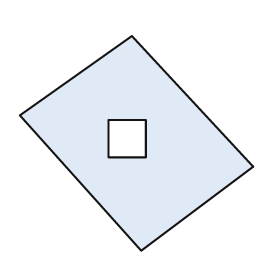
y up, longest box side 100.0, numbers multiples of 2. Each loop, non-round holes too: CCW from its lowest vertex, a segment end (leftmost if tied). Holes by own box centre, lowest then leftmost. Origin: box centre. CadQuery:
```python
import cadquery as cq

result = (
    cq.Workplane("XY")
    .moveTo(2.0, -46.0)
    .lineTo(50.0, -10.0)
    .lineTo(-2.0, 46.0)
    .lineTo(-50.0, 12.0)
    .close()
    .moveTo(-12.0, -6.0)
    .lineTo(4.0, -6.0)
    .lineTo(4.0, 10.0)
    .lineTo(-12.0, 10.0)
    .close()
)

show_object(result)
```